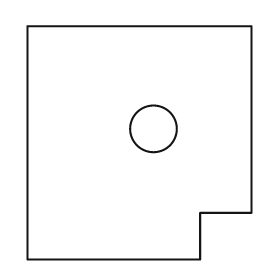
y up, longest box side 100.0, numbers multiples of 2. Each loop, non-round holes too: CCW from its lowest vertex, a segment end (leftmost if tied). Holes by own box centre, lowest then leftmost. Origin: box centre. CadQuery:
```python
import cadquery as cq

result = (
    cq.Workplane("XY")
    .moveTo(-48.0, -50.0)
    .lineTo(26.0, -50.0)
    .lineTo(26.0, -30.0)
    .lineTo(48.0, -30.0)
    .lineTo(48.0, 50.0)
    .lineTo(-48.0, 50.0)
    .close()
    .moveTo(6.0, 6.0)
    .circle(10.0)
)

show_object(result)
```